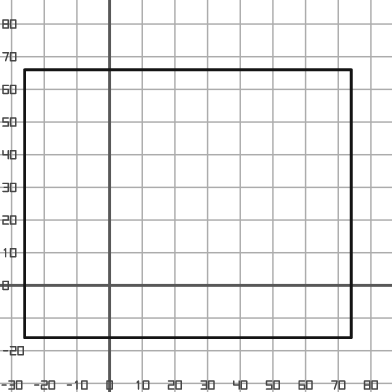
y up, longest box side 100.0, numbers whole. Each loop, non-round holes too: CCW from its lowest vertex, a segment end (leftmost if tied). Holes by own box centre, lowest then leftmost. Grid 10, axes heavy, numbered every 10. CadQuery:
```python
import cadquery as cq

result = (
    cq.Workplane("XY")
    .moveTo(-26.0, -16.0)
    .lineTo(74.0, -16.0)
    .lineTo(74.0, 66.0)
    .lineTo(-26.0, 66.0)
    .close()
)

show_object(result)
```